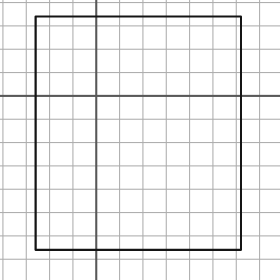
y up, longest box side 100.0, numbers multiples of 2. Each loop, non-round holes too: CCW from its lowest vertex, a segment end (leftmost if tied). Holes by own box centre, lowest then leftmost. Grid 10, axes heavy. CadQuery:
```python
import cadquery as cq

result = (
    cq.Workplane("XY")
    .moveTo(-26.0, -66.0)
    .lineTo(62.0, -66.0)
    .lineTo(62.0, 34.0)
    .lineTo(-26.0, 34.0)
    .close()
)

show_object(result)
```